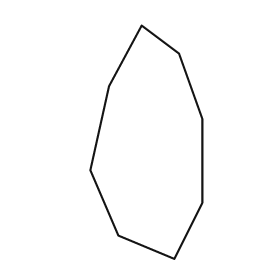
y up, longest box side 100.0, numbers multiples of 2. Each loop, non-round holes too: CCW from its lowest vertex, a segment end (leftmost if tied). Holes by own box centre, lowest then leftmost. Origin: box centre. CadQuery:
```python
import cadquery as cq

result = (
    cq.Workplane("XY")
    .moveTo(12.0, -50.0)
    .lineTo(24.0, -26.0)
    .lineTo(24.0, 10.0)
    .lineTo(14.0, 38.0)
    .lineTo(-2.0, 50.0)
    .lineTo(-16.0, 24.0)
    .lineTo(-24.0, -12.0)
    .lineTo(-12.0, -40.0)
    .close()
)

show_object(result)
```